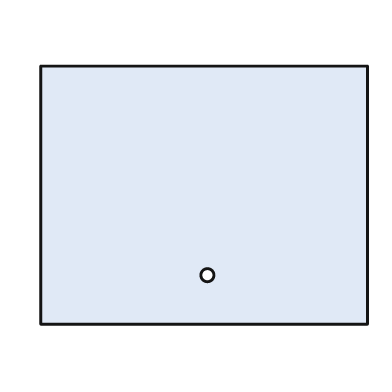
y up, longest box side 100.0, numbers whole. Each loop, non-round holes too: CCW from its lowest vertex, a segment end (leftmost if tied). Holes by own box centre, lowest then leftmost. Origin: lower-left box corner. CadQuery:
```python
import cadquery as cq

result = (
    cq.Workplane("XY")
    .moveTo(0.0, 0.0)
    .lineTo(100.0, 0.0)
    .lineTo(100.0, 79.0)
    .lineTo(0.0, 79.0)
    .close()
    .moveTo(51.0, 15.0)
    .circle(2.0)
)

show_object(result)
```